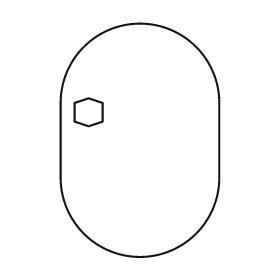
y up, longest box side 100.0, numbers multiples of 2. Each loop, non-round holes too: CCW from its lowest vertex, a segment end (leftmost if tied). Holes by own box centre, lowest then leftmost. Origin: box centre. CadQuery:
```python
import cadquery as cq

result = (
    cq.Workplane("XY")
    .moveTo(-34.0, -16.0)
    .threePointArc((0.0, -50.0), (34.0, -16.0))
    .lineTo(34.0, 16.0)
    .threePointArc((0.0, 50.0), (-34.0, 16.0))
    .close()
    .moveTo(-22.0, 6.0)
    .lineTo(-16.0, 8.0)
    .lineTo(-16.0, 16.0)
    .lineTo(-22.0, 18.0)
    .lineTo(-28.0, 16.0)
    .lineTo(-28.0, 8.0)
    .close()
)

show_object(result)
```